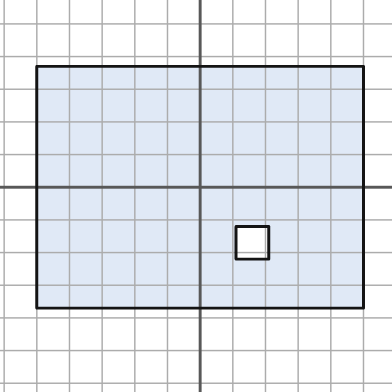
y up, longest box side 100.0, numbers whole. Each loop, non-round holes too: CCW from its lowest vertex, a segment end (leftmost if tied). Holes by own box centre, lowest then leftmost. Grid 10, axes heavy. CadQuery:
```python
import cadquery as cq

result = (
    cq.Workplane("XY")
    .moveTo(-50.0, -37.0)
    .lineTo(50.0, -37.0)
    .lineTo(50.0, 37.0)
    .lineTo(-50.0, 37.0)
    .close()
    .moveTo(11.0, -22.0)
    .lineTo(21.0, -22.0)
    .lineTo(21.0, -12.0)
    .lineTo(11.0, -12.0)
    .close()
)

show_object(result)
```